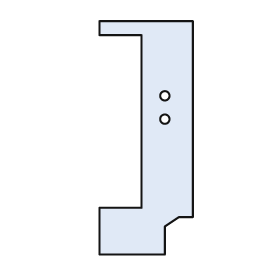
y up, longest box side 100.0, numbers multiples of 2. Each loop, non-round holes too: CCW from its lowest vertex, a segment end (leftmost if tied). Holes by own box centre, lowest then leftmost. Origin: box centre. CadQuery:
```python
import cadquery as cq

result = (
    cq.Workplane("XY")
    .moveTo(-20.0, -50.0)
    .lineTo(8.0, -50.0)
    .lineTo(8.0, -38.0)
    .lineTo(14.0, -34.0)
    .lineTo(20.0, -34.0)
    .lineTo(20.0, 50.0)
    .lineTo(-20.0, 50.0)
    .lineTo(-20.0, 44.0)
    .lineTo(-2.0, 44.0)
    .lineTo(-2.0, -30.0)
    .lineTo(-20.0, -30.0)
    .close()
    .moveTo(8.0, 8.0)
    .circle(2.0)
    .moveTo(8.0, 18.0)
    .circle(2.0)
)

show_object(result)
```